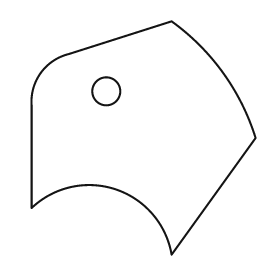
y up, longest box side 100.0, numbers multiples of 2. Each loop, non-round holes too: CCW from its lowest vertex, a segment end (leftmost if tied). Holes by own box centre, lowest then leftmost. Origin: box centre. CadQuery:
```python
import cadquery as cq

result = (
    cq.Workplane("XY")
    .moveTo(12.0, -50.0)
    .lineTo(48.0, 0.0)
    .threePointArc((34.0, 28.0), (12.0, 50.0))
    .lineTo(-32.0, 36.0)
    .threePointArc((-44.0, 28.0), (-48.0, 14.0))
    .lineTo(-48.0, -30.0)
    .threePointArc((-12.0, -22.0), (12.0, -50.0))
    .close()
    .moveTo(-16.0, 20.0)
    .circle(6.0)
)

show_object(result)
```